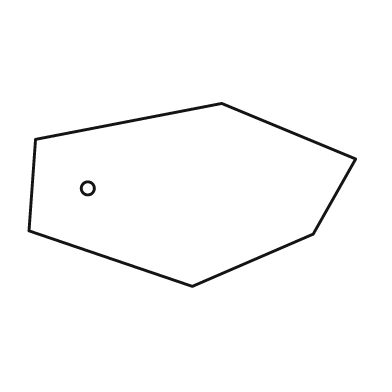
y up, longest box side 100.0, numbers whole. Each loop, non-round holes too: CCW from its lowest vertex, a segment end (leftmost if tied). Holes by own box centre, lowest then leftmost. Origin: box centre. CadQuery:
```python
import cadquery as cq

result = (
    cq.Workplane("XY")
    .moveTo(0.0, -28.0)
    .lineTo(37.0, -12.0)
    .lineTo(50.0, 11.0)
    .lineTo(9.0, 28.0)
    .lineTo(-48.0, 17.0)
    .lineTo(-50.0, -11.0)
    .close()
    .moveTo(-32.0, 2.0)
    .circle(2.0)
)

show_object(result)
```